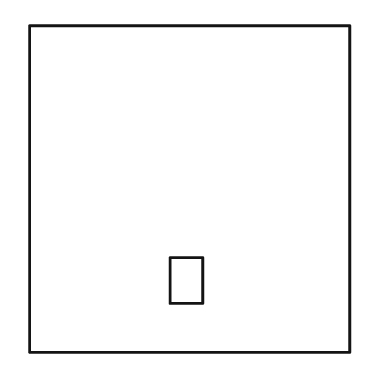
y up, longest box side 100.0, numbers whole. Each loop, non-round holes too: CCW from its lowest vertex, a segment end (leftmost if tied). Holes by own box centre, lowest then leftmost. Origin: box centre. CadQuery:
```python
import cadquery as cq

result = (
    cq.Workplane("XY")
    .moveTo(-49.0, -50.0)
    .lineTo(49.0, -50.0)
    .lineTo(49.0, 50.0)
    .lineTo(-49.0, 50.0)
    .close()
    .moveTo(-6.0, -35.0)
    .lineTo(4.0, -35.0)
    .lineTo(4.0, -21.0)
    .lineTo(-6.0, -21.0)
    .close()
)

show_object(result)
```